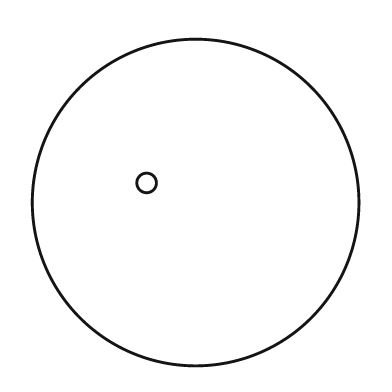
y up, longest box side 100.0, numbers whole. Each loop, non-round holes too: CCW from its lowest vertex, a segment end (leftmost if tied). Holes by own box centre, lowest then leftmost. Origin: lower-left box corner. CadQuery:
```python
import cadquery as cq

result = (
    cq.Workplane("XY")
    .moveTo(50.0, 50.0)
    .circle(50.0)
    .moveTo(35.0, 56.0)
    .circle(3.0)
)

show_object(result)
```